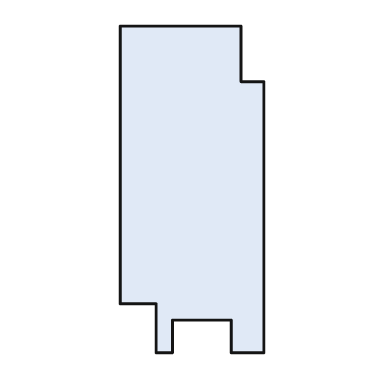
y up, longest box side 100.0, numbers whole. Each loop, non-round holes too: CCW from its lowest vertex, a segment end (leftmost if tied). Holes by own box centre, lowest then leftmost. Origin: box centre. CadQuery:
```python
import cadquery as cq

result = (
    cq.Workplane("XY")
    .moveTo(-11.0, -50.0)
    .lineTo(-6.0, -50.0)
    .lineTo(-6.0, -40.0)
    .lineTo(12.0, -40.0)
    .lineTo(12.0, -50.0)
    .lineTo(22.0, -50.0)
    .lineTo(22.0, 33.0)
    .lineTo(15.0, 33.0)
    .lineTo(15.0, 50.0)
    .lineTo(-22.0, 50.0)
    .lineTo(-22.0, -35.0)
    .lineTo(-11.0, -35.0)
    .close()
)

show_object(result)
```